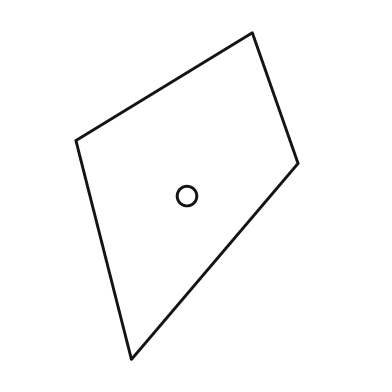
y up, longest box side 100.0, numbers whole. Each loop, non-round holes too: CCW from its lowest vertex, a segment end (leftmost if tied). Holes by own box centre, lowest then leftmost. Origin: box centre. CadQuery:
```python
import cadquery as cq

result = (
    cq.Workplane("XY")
    .moveTo(-17.0, -50.0)
    .lineTo(34.0, 10.0)
    .lineTo(20.0, 50.0)
    .lineTo(-34.0, 17.0)
    .close()
    .moveTo(0.0, 0.0)
    .circle(3.0)
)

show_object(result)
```